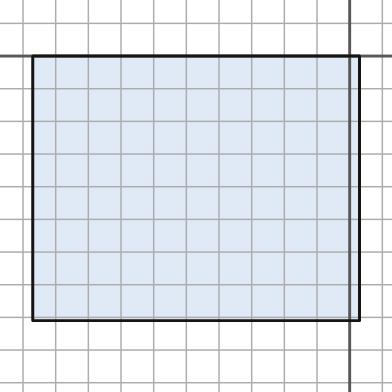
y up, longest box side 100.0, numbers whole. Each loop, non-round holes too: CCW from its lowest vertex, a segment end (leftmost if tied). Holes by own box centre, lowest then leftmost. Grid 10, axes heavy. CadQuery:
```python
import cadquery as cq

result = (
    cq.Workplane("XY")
    .moveTo(-97.0, -81.0)
    .lineTo(3.0, -81.0)
    .lineTo(3.0, 0.0)
    .lineTo(-97.0, 0.0)
    .close()
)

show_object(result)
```